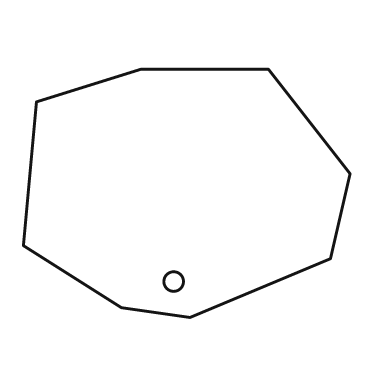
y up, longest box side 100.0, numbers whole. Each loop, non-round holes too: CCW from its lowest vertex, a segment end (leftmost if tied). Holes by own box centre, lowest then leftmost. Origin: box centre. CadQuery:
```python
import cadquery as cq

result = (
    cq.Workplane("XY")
    .moveTo(1.0, -38.0)
    .lineTo(44.0, -20.0)
    .lineTo(50.0, 6.0)
    .lineTo(25.0, 38.0)
    .lineTo(-14.0, 38.0)
    .lineTo(-46.0, 28.0)
    .lineTo(-50.0, -16.0)
    .lineTo(-20.0, -35.0)
    .close()
    .moveTo(-4.0, -27.0)
    .circle(3.0)
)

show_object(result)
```